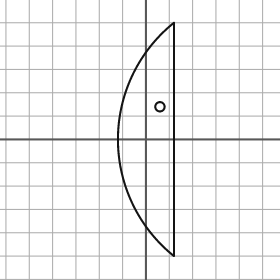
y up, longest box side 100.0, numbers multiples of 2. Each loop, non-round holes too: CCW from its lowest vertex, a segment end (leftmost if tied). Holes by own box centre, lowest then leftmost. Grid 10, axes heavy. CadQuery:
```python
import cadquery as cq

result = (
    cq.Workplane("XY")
    .moveTo(12.0, -50.0)
    .lineTo(12.0, 50.0)
    .threePointArc((-12.0, 0.0), (12.0, -50.0))
    .close()
    .moveTo(6.0, 14.0)
    .circle(2.0)
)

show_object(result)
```